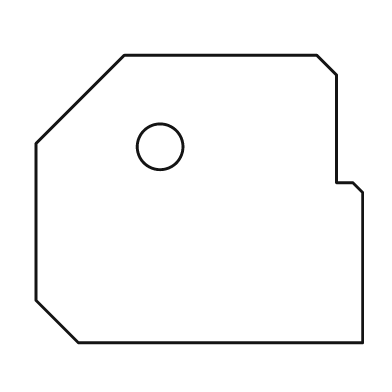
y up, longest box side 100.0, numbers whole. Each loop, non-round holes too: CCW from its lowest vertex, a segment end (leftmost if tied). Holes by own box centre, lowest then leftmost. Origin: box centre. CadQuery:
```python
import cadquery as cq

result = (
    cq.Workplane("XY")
    .moveTo(-37.0, -44.0)
    .lineTo(50.0, -44.0)
    .lineTo(50.0, 2.0)
    .lineTo(47.0, 5.0)
    .lineTo(42.0, 5.0)
    .lineTo(42.0, 38.0)
    .lineTo(36.0, 44.0)
    .lineTo(-23.0, 44.0)
    .lineTo(-50.0, 17.0)
    .lineTo(-50.0, -31.0)
    .close()
    .moveTo(-12.0, 16.0)
    .circle(7.0)
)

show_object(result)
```